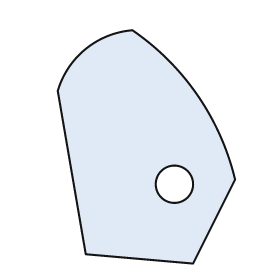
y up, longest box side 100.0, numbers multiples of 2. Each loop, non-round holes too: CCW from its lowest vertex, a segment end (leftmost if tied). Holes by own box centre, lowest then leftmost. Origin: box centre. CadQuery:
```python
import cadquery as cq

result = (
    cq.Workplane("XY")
    .moveTo(20.0, -50.0)
    .lineTo(38.0, -14.0)
    .threePointArc((22.0, 22.0), (-6.0, 50.0))
    .threePointArc((-26.0, 42.0), (-38.0, 24.0))
    .lineTo(-26.0, -46.0)
    .close()
    .moveTo(12.0, -16.0)
    .circle(8.0)
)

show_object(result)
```